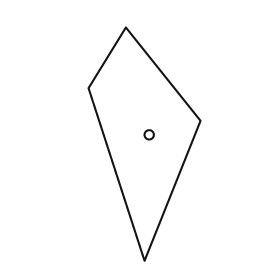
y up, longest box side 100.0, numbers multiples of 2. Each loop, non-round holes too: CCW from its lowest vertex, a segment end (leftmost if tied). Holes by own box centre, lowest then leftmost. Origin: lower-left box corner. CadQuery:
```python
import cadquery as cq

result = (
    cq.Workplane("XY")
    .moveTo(24.0, 0.0)
    .lineTo(48.0, 60.0)
    .lineTo(16.0, 100.0)
    .lineTo(0.0, 74.0)
    .close()
    .moveTo(26.0, 54.0)
    .circle(2.0)
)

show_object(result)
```